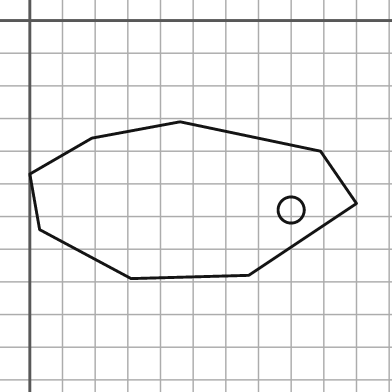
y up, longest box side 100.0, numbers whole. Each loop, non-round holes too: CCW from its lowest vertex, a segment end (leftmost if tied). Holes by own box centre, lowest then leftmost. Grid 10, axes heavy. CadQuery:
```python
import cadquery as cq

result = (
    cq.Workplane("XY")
    .moveTo(31.0, -79.0)
    .lineTo(67.0, -78.0)
    .lineTo(100.0, -56.0)
    .lineTo(89.0, -40.0)
    .lineTo(46.0, -31.0)
    .lineTo(19.0, -36.0)
    .lineTo(0.0, -47.0)
    .lineTo(3.0, -64.0)
    .close()
    .moveTo(80.0, -58.0)
    .circle(4.0)
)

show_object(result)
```